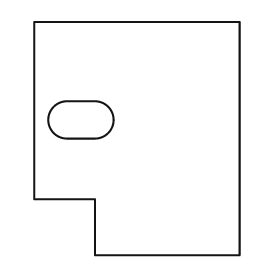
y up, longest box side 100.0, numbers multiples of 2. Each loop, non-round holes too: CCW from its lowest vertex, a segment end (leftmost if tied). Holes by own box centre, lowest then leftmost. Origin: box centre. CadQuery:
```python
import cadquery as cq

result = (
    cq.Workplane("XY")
    .moveTo(-18.0, -50.0)
    .lineTo(44.0, -50.0)
    .lineTo(44.0, 50.0)
    .lineTo(-44.0, 50.0)
    .lineTo(-44.0, -26.0)
    .lineTo(-18.0, -26.0)
    .close()
    .moveTo(-30.0, 0.0)
    .lineTo(-18.0, 0.0)
    .threePointArc((-10.0, 8.0), (-18.0, 16.0))
    .lineTo(-30.0, 16.0)
    .threePointArc((-38.0, 8.0), (-30.0, 0.0))
    .close()
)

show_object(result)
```